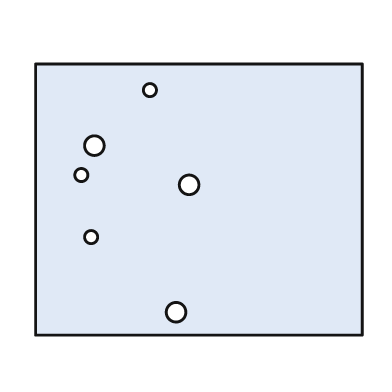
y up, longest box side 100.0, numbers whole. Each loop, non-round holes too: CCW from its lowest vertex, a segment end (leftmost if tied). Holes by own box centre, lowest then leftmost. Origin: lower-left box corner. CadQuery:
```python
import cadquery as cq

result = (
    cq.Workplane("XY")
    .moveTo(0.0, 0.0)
    .lineTo(100.0, 0.0)
    .lineTo(100.0, 83.0)
    .lineTo(0.0, 83.0)
    .close()
    .moveTo(43.0, 7.0)
    .circle(3.0)
    .moveTo(17.0, 30.0)
    .circle(2.0)
    .moveTo(47.0, 46.0)
    .circle(3.0)
    .moveTo(14.0, 49.0)
    .circle(2.0)
    .moveTo(18.0, 58.0)
    .circle(3.0)
    .moveTo(35.0, 75.0)
    .circle(2.0)
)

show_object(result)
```